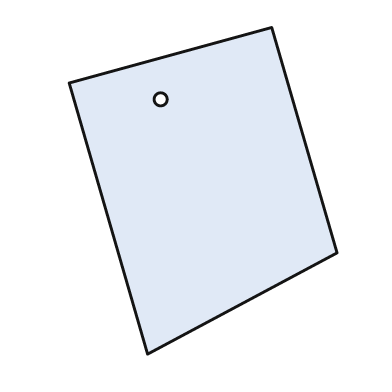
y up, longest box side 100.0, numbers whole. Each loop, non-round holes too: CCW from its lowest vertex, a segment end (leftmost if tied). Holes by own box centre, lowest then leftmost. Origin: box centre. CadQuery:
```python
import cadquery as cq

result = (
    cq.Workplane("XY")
    .moveTo(-17.0, -50.0)
    .lineTo(41.0, -19.0)
    .lineTo(21.0, 50.0)
    .lineTo(-41.0, 33.0)
    .close()
    .moveTo(-13.0, 28.0)
    .circle(2.0)
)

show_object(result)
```